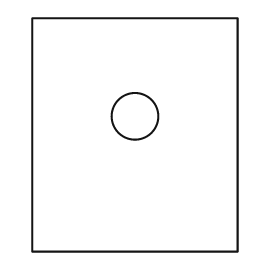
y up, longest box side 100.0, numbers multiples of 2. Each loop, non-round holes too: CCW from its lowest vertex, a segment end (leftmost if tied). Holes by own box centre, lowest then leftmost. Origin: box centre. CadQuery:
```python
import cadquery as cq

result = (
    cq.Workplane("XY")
    .moveTo(-44.0, -50.0)
    .lineTo(44.0, -50.0)
    .lineTo(44.0, 50.0)
    .lineTo(-44.0, 50.0)
    .close()
    .moveTo(0.0, 8.0)
    .circle(10.0)
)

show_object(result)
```